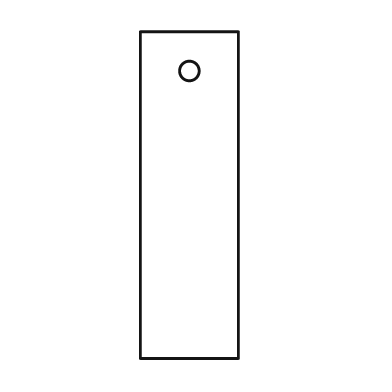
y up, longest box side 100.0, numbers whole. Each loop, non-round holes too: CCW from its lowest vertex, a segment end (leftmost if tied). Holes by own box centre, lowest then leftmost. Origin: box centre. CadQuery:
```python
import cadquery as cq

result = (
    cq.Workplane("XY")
    .moveTo(-15.0, -50.0)
    .lineTo(15.0, -50.0)
    .lineTo(15.0, 50.0)
    .lineTo(-15.0, 50.0)
    .close()
    .moveTo(0.0, 38.0)
    .circle(3.0)
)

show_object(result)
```